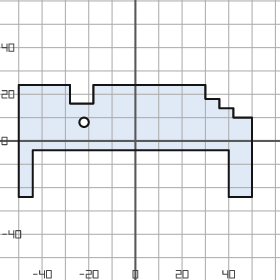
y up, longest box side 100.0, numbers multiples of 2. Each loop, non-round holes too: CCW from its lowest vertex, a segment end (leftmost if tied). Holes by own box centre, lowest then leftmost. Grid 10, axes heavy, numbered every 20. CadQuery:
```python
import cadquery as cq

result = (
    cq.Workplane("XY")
    .moveTo(-50.0, -24.0)
    .lineTo(-44.0, -24.0)
    .lineTo(-44.0, -4.0)
    .lineTo(40.0, -4.0)
    .lineTo(40.0, -24.0)
    .lineTo(50.0, -24.0)
    .lineTo(50.0, 10.0)
    .lineTo(42.0, 10.0)
    .lineTo(42.0, 14.0)
    .lineTo(36.0, 14.0)
    .lineTo(36.0, 18.0)
    .lineTo(30.0, 18.0)
    .lineTo(30.0, 24.0)
    .lineTo(-18.0, 24.0)
    .lineTo(-18.0, 16.0)
    .lineTo(-28.0, 16.0)
    .lineTo(-28.0, 24.0)
    .lineTo(-50.0, 24.0)
    .close()
    .moveTo(-22.0, 8.0)
    .circle(2.0)
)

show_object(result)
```